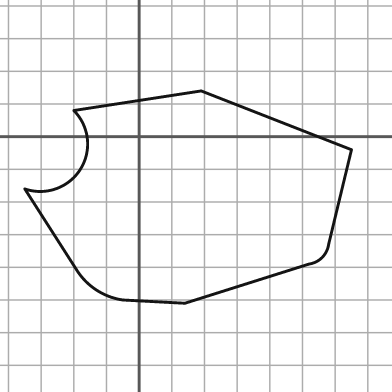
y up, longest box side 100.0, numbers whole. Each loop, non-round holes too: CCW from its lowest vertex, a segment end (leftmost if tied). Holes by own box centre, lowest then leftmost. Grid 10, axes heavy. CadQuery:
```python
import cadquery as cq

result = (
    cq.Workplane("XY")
    .moveTo(14.0, -51.0)
    .lineTo(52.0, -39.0)
    .threePointArc((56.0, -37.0), (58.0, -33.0))
    .lineTo(65.0, -4.0)
    .lineTo(19.0, 14.0)
    .lineTo(-20.0, 8.0)
    .threePointArc((-18.0, -10.0), (-35.0, -16.0))
    .lineTo(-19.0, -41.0)
    .threePointArc((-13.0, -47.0), (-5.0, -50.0))
    .close()
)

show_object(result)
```